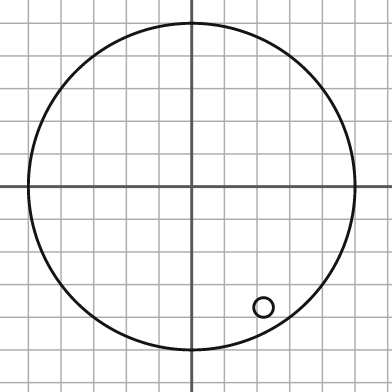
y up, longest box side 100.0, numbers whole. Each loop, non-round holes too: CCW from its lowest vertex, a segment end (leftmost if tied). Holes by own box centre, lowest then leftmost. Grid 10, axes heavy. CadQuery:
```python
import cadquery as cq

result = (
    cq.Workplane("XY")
    .moveTo(0.0, 0.0)
    .circle(50.0)
    .moveTo(22.0, -37.0)
    .circle(3.0)
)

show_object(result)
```